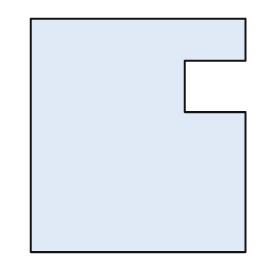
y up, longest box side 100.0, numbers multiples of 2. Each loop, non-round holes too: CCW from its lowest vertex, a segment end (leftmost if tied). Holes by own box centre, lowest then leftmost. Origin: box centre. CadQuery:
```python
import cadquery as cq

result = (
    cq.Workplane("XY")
    .moveTo(-46.0, -50.0)
    .lineTo(46.0, -50.0)
    .lineTo(46.0, 10.0)
    .lineTo(20.0, 10.0)
    .lineTo(20.0, 32.0)
    .lineTo(46.0, 32.0)
    .lineTo(46.0, 50.0)
    .lineTo(-46.0, 50.0)
    .close()
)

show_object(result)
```